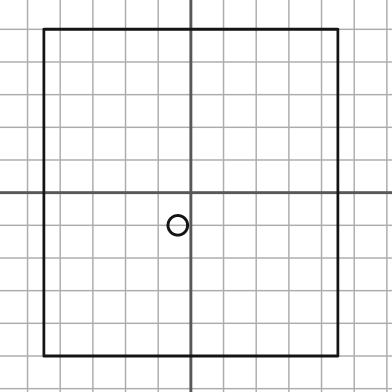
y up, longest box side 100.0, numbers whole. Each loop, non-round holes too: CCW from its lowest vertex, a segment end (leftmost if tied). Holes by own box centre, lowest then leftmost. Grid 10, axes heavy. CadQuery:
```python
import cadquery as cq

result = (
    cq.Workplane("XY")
    .moveTo(-45.0, -50.0)
    .lineTo(45.0, -50.0)
    .lineTo(45.0, 50.0)
    .lineTo(-45.0, 50.0)
    .close()
    .moveTo(-4.0, -10.0)
    .circle(3.0)
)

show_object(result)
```